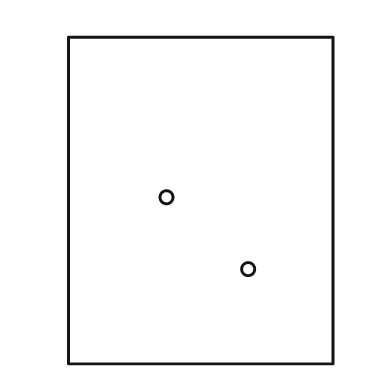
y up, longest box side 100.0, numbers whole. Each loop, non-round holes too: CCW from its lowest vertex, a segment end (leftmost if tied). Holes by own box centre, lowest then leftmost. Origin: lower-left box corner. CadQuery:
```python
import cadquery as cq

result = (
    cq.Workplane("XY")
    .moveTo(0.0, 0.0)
    .lineTo(81.0, 0.0)
    .lineTo(81.0, 100.0)
    .lineTo(0.0, 100.0)
    .close()
    .moveTo(55.0, 29.0)
    .circle(2.0)
    .moveTo(30.0, 51.0)
    .circle(2.0)
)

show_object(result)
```